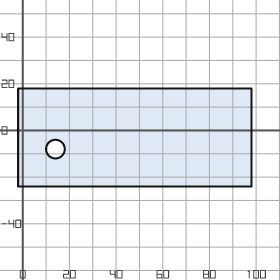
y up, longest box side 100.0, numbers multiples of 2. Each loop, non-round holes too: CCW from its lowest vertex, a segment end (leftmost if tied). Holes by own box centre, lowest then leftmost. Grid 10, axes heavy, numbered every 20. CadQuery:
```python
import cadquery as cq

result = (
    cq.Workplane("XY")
    .moveTo(-2.0, -24.0)
    .lineTo(98.0, -24.0)
    .lineTo(98.0, 18.0)
    .lineTo(-2.0, 18.0)
    .close()
    .moveTo(14.0, -8.0)
    .circle(4.0)
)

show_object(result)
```